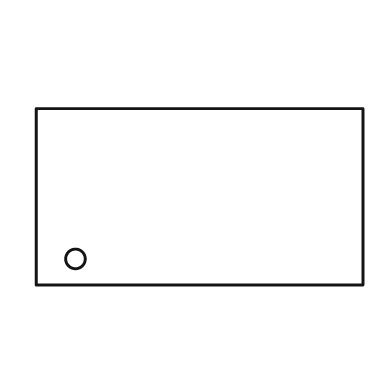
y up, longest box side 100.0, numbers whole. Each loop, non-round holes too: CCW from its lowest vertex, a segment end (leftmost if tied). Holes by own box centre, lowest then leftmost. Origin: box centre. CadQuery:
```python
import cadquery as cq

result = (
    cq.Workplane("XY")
    .moveTo(-50.0, -27.0)
    .lineTo(50.0, -27.0)
    .lineTo(50.0, 27.0)
    .lineTo(-50.0, 27.0)
    .close()
    .moveTo(-38.0, -19.0)
    .circle(3.0)
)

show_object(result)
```